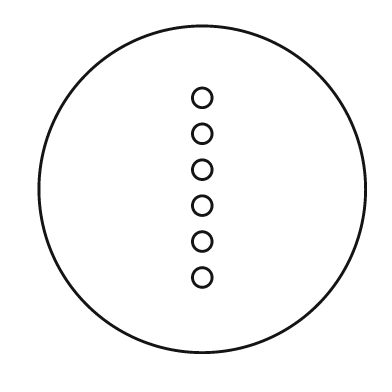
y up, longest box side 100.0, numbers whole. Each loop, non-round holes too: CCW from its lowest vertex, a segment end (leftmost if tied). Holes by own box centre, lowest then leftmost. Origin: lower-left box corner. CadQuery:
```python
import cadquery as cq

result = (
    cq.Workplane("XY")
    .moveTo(50.0, 50.0)
    .circle(50.0)
    .moveTo(50.0, 23.0)
    .circle(3.0)
    .moveTo(50.0, 34.0)
    .circle(3.0)
    .moveTo(50.0, 45.0)
    .circle(3.0)
    .moveTo(50.0, 56.0)
    .circle(3.0)
    .moveTo(50.0, 67.0)
    .circle(3.0)
    .moveTo(50.0, 78.0)
    .circle(3.0)
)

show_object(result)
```